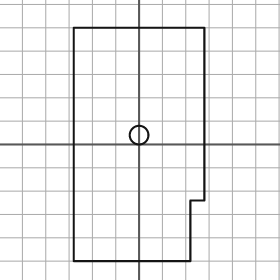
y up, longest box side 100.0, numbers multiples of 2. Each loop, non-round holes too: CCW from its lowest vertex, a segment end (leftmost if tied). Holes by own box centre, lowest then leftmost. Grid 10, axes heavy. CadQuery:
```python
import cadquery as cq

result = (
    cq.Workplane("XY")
    .moveTo(-28.0, -50.0)
    .lineTo(22.0, -50.0)
    .lineTo(22.0, -24.0)
    .lineTo(28.0, -24.0)
    .lineTo(28.0, 50.0)
    .lineTo(-28.0, 50.0)
    .close()
    .moveTo(0.0, 4.0)
    .circle(4.0)
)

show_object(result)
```